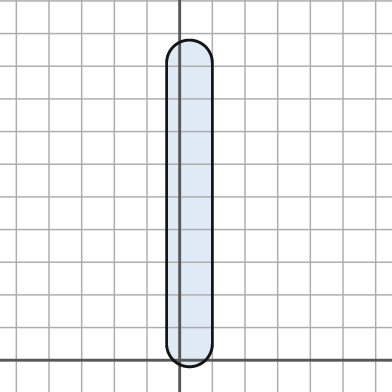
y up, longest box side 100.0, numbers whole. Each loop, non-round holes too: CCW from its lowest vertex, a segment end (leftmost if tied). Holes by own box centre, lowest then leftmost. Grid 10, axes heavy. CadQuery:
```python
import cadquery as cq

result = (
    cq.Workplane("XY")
    .moveTo(-4.0, 5.0)
    .threePointArc((3.0, -2.0), (10.0, 5.0))
    .lineTo(10.0, 91.0)
    .threePointArc((3.0, 98.0), (-4.0, 91.0))
    .close()
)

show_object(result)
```